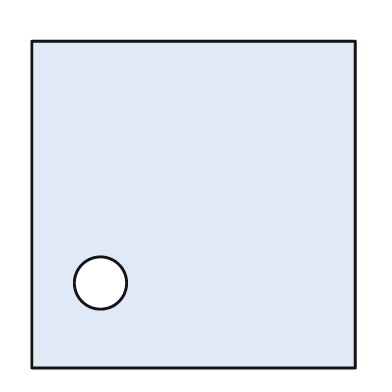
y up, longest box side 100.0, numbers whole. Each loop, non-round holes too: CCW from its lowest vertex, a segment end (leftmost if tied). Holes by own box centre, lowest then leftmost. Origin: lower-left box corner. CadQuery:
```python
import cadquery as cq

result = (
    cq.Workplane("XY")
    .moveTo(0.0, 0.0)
    .lineTo(99.0, 0.0)
    .lineTo(99.0, 100.0)
    .lineTo(0.0, 100.0)
    .close()
    .moveTo(21.0, 26.0)
    .circle(8.0)
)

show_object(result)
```